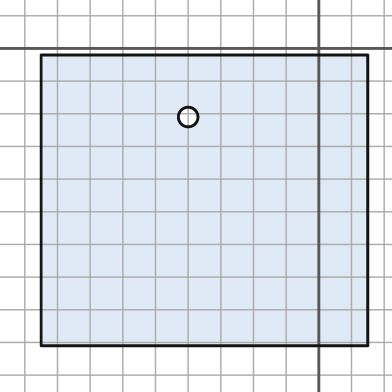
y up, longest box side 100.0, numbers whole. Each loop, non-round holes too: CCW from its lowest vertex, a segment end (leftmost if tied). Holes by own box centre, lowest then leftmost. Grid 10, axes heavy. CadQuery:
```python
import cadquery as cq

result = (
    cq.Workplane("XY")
    .moveTo(-85.0, -91.0)
    .lineTo(15.0, -91.0)
    .lineTo(15.0, -2.0)
    .lineTo(-85.0, -2.0)
    .close()
    .moveTo(-40.0, -21.0)
    .circle(3.0)
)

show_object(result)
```